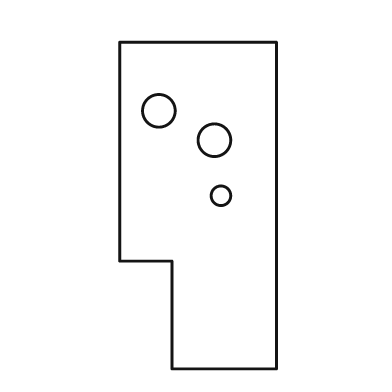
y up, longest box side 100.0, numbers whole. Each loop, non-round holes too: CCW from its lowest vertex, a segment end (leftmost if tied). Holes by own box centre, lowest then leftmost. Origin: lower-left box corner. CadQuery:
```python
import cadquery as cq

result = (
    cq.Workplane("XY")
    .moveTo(16.0, 0.0)
    .lineTo(48.0, 0.0)
    .lineTo(48.0, 100.0)
    .lineTo(0.0, 100.0)
    .lineTo(0.0, 33.0)
    .lineTo(16.0, 33.0)
    .close()
    .moveTo(31.0, 53.0)
    .circle(3.0)
    .moveTo(29.0, 70.0)
    .circle(5.0)
    .moveTo(12.0, 79.0)
    .circle(5.0)
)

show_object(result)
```